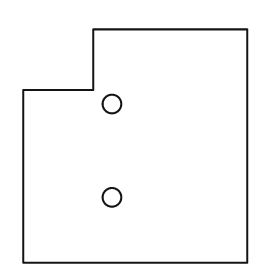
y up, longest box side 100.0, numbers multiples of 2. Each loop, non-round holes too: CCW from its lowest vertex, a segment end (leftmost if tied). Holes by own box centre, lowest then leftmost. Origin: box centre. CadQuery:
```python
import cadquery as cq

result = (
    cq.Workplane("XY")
    .moveTo(-48.0, -50.0)
    .lineTo(48.0, -50.0)
    .lineTo(48.0, 50.0)
    .lineTo(-18.0, 50.0)
    .lineTo(-18.0, 24.0)
    .lineTo(-48.0, 24.0)
    .close()
    .moveTo(-10.0, -22.0)
    .circle(4.0)
    .moveTo(-10.0, 18.0)
    .circle(4.0)
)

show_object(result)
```